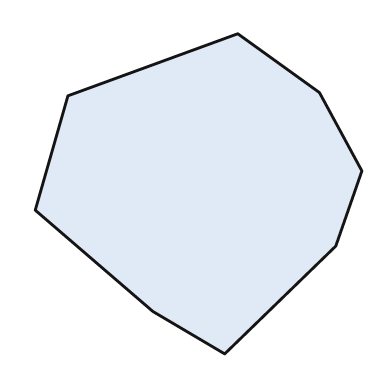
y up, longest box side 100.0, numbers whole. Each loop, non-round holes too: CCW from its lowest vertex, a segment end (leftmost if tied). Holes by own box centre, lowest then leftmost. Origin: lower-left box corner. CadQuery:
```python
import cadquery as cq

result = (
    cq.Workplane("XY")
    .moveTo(58.0, 0.0)
    .lineTo(92.0, 33.0)
    .lineTo(100.0, 56.0)
    .lineTo(87.0, 80.0)
    .lineTo(62.0, 98.0)
    .lineTo(10.0, 79.0)
    .lineTo(0.0, 44.0)
    .lineTo(36.0, 13.0)
    .close()
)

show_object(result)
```